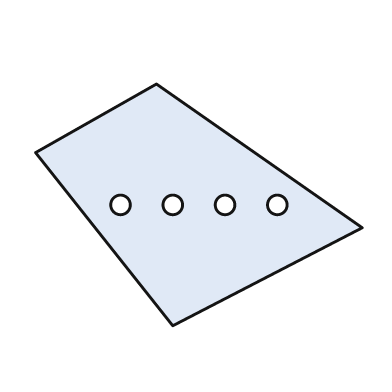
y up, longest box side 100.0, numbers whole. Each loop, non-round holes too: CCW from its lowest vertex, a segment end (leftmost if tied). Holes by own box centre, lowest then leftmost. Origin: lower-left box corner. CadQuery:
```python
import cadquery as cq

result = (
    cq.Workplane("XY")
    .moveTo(42.0, 0.0)
    .lineTo(100.0, 30.0)
    .lineTo(37.0, 74.0)
    .lineTo(0.0, 53.0)
    .close()
    .moveTo(26.0, 37.0)
    .circle(3.0)
    .moveTo(42.0, 37.0)
    .circle(3.0)
    .moveTo(58.0, 37.0)
    .circle(3.0)
    .moveTo(74.0, 37.0)
    .circle(3.0)
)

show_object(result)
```